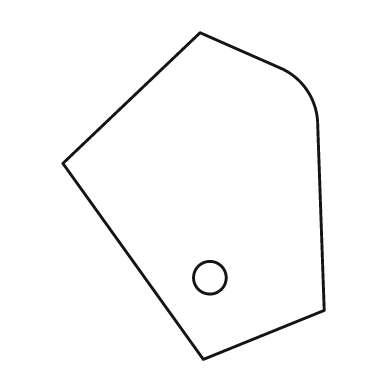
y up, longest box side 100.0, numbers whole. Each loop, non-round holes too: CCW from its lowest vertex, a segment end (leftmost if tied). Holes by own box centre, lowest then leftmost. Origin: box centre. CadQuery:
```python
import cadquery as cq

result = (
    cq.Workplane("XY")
    .moveTo(3.0, -50.0)
    .lineTo(40.0, -35.0)
    .lineTo(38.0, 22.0)
    .threePointArc((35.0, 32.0), (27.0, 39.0))
    .lineTo(2.0, 50.0)
    .lineTo(-40.0, 10.0)
    .close()
    .moveTo(5.0, -25.0)
    .circle(5.0)
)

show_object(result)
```